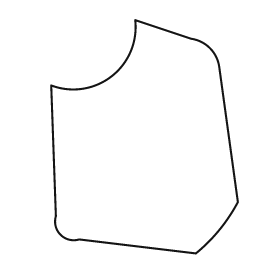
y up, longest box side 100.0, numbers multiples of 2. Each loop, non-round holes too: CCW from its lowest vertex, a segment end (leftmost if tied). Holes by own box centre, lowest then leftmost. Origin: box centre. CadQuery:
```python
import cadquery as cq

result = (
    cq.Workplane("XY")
    .moveTo(22.0, -50.0)
    .threePointArc((32.0, -40.0), (40.0, -28.0))
    .lineTo(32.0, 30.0)
    .threePointArc((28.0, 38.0), (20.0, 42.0))
    .lineTo(-4.0, 50.0)
    .threePointArc((-14.0, 26.0), (-40.0, 22.0))
    .lineTo(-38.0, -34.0)
    .threePointArc((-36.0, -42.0), (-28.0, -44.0))
    .close()
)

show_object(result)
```